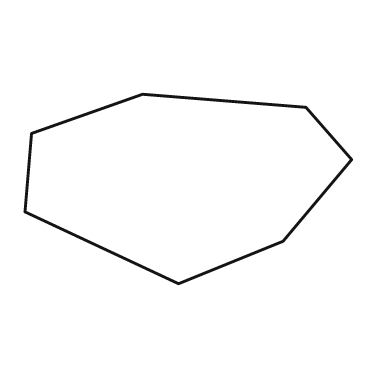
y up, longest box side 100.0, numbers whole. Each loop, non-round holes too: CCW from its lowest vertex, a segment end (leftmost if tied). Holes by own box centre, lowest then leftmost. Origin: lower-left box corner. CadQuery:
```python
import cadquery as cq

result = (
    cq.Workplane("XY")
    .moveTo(47.0, 0.0)
    .lineTo(79.0, 13.0)
    .lineTo(100.0, 38.0)
    .lineTo(86.0, 54.0)
    .lineTo(36.0, 58.0)
    .lineTo(2.0, 46.0)
    .lineTo(0.0, 22.0)
    .close()
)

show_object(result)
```